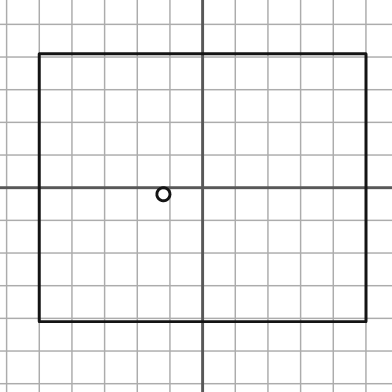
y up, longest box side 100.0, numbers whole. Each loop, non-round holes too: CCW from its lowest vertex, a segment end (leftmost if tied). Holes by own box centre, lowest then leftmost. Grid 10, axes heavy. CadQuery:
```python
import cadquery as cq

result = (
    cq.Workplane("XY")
    .moveTo(-50.0, -41.0)
    .lineTo(50.0, -41.0)
    .lineTo(50.0, 41.0)
    .lineTo(-50.0, 41.0)
    .close()
    .moveTo(-12.0, -2.0)
    .circle(2.0)
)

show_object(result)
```